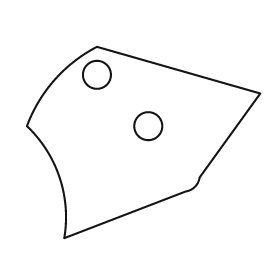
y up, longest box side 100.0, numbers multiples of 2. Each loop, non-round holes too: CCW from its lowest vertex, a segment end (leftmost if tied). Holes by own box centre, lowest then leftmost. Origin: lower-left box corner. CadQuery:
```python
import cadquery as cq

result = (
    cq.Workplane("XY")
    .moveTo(16.0, 0.0)
    .lineTo(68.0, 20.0)
    .threePointArc((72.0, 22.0), (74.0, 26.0))
    .lineTo(100.0, 62.0)
    .lineTo(30.0, 82.0)
    .threePointArc((12.0, 68.0), (0.0, 48.0))
    .threePointArc((14.0, 26.0), (16.0, 0.0))
    .close()
    .moveTo(52.0, 48.0)
    .circle(6.0)
    .moveTo(30.0, 70.0)
    .circle(6.0)
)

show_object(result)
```